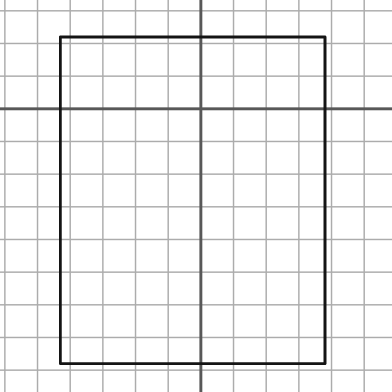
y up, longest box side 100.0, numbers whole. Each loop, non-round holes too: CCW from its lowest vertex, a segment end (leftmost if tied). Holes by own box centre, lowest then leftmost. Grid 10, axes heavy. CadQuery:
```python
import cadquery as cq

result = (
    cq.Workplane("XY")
    .moveTo(-43.0, -78.0)
    .lineTo(38.0, -78.0)
    .lineTo(38.0, 22.0)
    .lineTo(-43.0, 22.0)
    .close()
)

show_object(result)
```